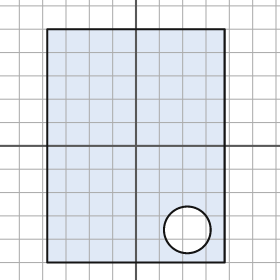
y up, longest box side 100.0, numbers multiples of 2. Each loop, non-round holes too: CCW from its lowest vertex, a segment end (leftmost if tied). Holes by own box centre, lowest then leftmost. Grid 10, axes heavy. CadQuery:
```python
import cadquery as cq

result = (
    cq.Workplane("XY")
    .moveTo(-38.0, -50.0)
    .lineTo(38.0, -50.0)
    .lineTo(38.0, 50.0)
    .lineTo(-38.0, 50.0)
    .close()
    .moveTo(22.0, -36.0)
    .circle(10.0)
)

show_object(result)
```